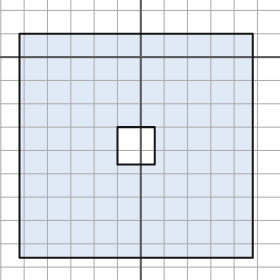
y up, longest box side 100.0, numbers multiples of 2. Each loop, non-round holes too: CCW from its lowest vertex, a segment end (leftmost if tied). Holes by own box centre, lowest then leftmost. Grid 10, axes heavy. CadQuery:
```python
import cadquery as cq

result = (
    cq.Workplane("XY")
    .moveTo(-52.0, -86.0)
    .lineTo(48.0, -86.0)
    .lineTo(48.0, 10.0)
    .lineTo(-52.0, 10.0)
    .close()
    .moveTo(-10.0, -46.0)
    .lineTo(6.0, -46.0)
    .lineTo(6.0, -30.0)
    .lineTo(-10.0, -30.0)
    .close()
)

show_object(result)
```